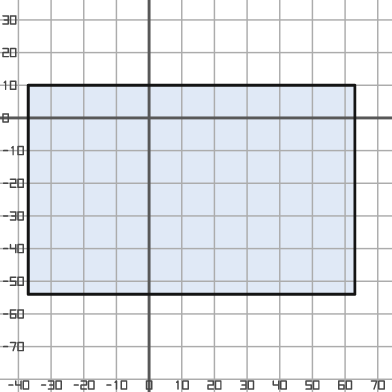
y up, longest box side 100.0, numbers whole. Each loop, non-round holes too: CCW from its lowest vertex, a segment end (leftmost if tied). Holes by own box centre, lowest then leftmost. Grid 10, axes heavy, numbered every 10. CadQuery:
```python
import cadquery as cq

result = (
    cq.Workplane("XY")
    .moveTo(-37.0, -54.0)
    .lineTo(63.0, -54.0)
    .lineTo(63.0, 10.0)
    .lineTo(-37.0, 10.0)
    .close()
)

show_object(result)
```